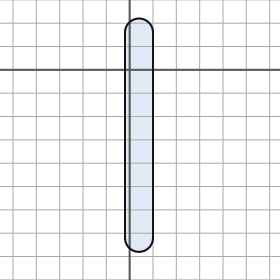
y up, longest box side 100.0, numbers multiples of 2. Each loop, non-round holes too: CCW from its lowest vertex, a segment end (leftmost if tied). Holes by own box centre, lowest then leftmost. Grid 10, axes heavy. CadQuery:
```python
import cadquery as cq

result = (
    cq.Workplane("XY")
    .moveTo(-2.0, -72.0)
    .threePointArc((4.0, -78.0), (10.0, -72.0))
    .lineTo(10.0, 16.0)
    .threePointArc((4.0, 22.0), (-2.0, 16.0))
    .close()
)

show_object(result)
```